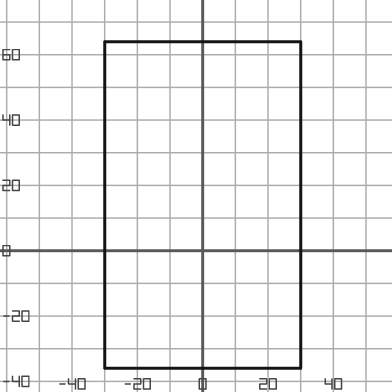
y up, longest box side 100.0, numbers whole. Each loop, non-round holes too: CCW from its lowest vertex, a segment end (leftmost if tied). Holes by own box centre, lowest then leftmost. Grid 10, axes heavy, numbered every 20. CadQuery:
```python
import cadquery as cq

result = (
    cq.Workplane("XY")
    .moveTo(-30.0, -36.0)
    .lineTo(30.0, -36.0)
    .lineTo(30.0, 64.0)
    .lineTo(-30.0, 64.0)
    .close()
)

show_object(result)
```